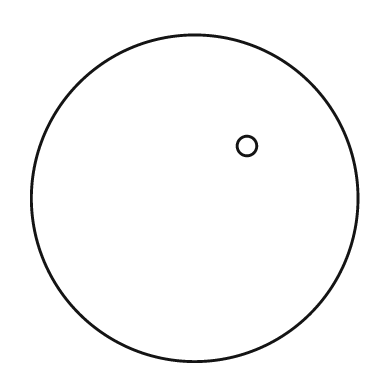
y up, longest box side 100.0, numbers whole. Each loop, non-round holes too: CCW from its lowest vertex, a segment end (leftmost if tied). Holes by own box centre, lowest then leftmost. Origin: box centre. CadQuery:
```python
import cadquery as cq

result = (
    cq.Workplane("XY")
    .moveTo(0.0, 0.0)
    .circle(50.0)
    .moveTo(16.0, 16.0)
    .circle(3.0)
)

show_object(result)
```